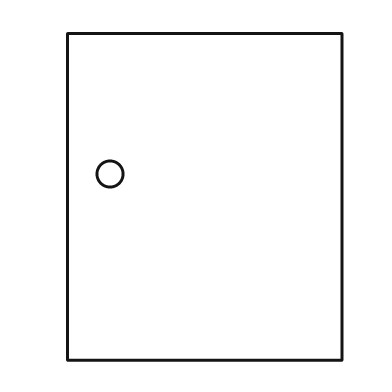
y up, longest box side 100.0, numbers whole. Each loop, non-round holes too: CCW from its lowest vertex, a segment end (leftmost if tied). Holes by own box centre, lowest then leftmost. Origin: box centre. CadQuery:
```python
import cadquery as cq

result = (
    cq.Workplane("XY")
    .moveTo(-42.0, -50.0)
    .lineTo(42.0, -50.0)
    .lineTo(42.0, 50.0)
    .lineTo(-42.0, 50.0)
    .close()
    .moveTo(-29.0, 7.0)
    .circle(4.0)
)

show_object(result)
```